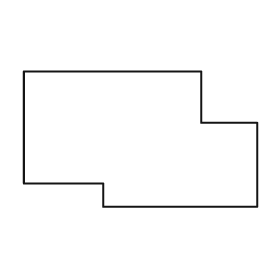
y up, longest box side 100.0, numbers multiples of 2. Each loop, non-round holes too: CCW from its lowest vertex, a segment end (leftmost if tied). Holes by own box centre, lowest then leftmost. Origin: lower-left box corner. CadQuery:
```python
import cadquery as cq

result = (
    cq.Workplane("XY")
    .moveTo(34.0, 0.0)
    .lineTo(100.0, 0.0)
    .lineTo(100.0, 36.0)
    .lineTo(76.0, 36.0)
    .lineTo(76.0, 58.0)
    .lineTo(0.0, 58.0)
    .lineTo(0.0, 10.0)
    .lineTo(34.0, 10.0)
    .close()
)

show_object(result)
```